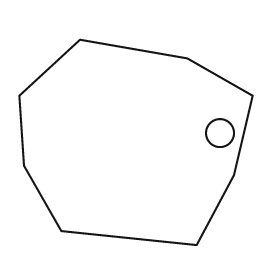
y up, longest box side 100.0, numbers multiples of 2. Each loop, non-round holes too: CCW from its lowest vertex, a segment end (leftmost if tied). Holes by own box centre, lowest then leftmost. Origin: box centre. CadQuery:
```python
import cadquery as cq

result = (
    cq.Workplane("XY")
    .moveTo(26.0, -44.0)
    .lineTo(42.0, -14.0)
    .lineTo(50.0, 20.0)
    .lineTo(22.0, 36.0)
    .lineTo(-24.0, 44.0)
    .lineTo(-50.0, 20.0)
    .lineTo(-48.0, -10.0)
    .lineTo(-32.0, -38.0)
    .close()
    .moveTo(36.0, 4.0)
    .circle(6.0)
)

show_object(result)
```